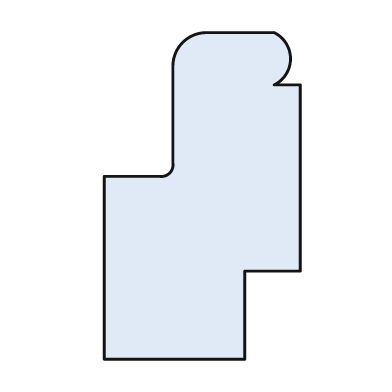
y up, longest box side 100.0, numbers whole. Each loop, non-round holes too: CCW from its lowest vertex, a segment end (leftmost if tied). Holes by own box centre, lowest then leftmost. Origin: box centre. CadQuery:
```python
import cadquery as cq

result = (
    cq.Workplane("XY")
    .moveTo(-30.0, -50.0)
    .lineTo(13.0, -50.0)
    .lineTo(13.0, -23.0)
    .lineTo(30.0, -23.0)
    .lineTo(30.0, 34.0)
    .lineTo(22.0, 34.0)
    .threePointArc((27.0, 42.0), (22.0, 50.0))
    .lineTo(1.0, 50.0)
    .threePointArc((-6.0, 47.0), (-9.0, 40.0))
    .lineTo(-9.0, 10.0)
    .threePointArc((-10.0, 7.0), (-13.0, 6.0))
    .lineTo(-30.0, 6.0)
    .close()
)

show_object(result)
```